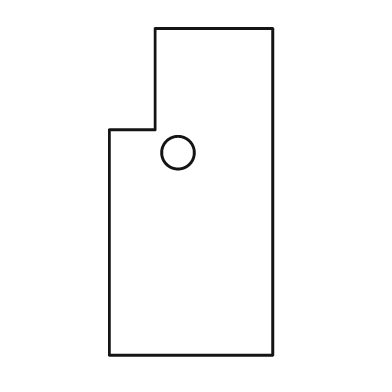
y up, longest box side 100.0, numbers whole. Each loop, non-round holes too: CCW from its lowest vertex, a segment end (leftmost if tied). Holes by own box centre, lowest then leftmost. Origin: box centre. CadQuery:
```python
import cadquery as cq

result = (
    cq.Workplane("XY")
    .moveTo(-25.0, -50.0)
    .lineTo(25.0, -50.0)
    .lineTo(25.0, 50.0)
    .lineTo(-11.0, 50.0)
    .lineTo(-11.0, 19.0)
    .lineTo(-25.0, 19.0)
    .close()
    .moveTo(-4.0, 12.0)
    .circle(5.0)
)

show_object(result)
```